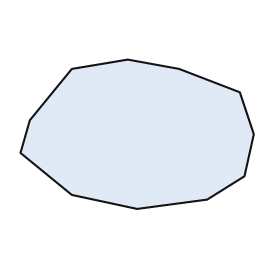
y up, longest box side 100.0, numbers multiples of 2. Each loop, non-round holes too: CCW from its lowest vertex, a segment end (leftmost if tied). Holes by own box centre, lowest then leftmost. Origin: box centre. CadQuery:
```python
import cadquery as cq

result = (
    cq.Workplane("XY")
    .moveTo(0.0, -32.0)
    .lineTo(30.0, -28.0)
    .lineTo(46.0, -18.0)
    .lineTo(50.0, 0.0)
    .lineTo(44.0, 18.0)
    .lineTo(18.0, 28.0)
    .lineTo(-4.0, 32.0)
    .lineTo(-28.0, 28.0)
    .lineTo(-46.0, 6.0)
    .lineTo(-50.0, -8.0)
    .lineTo(-28.0, -26.0)
    .close()
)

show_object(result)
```